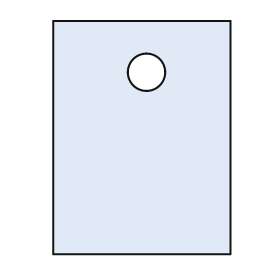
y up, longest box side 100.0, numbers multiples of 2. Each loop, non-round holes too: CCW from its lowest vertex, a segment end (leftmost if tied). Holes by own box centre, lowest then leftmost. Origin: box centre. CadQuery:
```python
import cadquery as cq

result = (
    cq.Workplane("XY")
    .moveTo(-38.0, -50.0)
    .lineTo(38.0, -50.0)
    .lineTo(38.0, 50.0)
    .lineTo(-38.0, 50.0)
    .close()
    .moveTo(2.0, 28.0)
    .circle(8.0)
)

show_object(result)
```